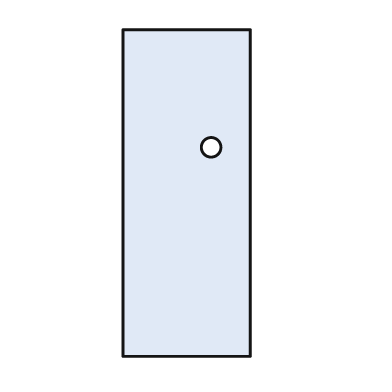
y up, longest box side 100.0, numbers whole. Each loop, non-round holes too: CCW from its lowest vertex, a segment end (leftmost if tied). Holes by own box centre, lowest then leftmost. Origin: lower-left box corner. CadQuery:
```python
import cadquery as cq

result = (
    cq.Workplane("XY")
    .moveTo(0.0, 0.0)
    .lineTo(39.0, 0.0)
    .lineTo(39.0, 100.0)
    .lineTo(0.0, 100.0)
    .close()
    .moveTo(27.0, 64.0)
    .circle(3.0)
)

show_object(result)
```